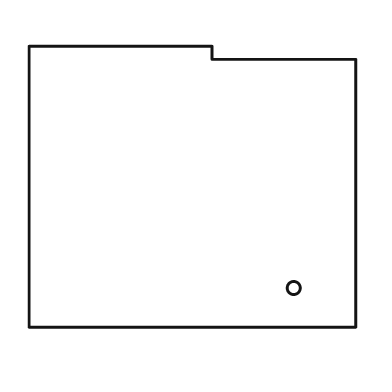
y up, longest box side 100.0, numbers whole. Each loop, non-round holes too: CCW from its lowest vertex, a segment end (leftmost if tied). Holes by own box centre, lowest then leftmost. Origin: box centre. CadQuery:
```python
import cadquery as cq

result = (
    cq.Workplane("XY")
    .moveTo(-50.0, -43.0)
    .lineTo(50.0, -43.0)
    .lineTo(50.0, 39.0)
    .lineTo(6.0, 39.0)
    .lineTo(6.0, 43.0)
    .lineTo(-50.0, 43.0)
    .close()
    .moveTo(31.0, -31.0)
    .circle(2.0)
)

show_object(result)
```